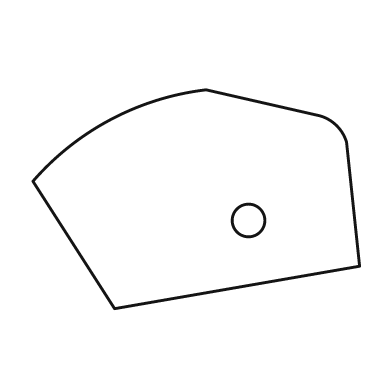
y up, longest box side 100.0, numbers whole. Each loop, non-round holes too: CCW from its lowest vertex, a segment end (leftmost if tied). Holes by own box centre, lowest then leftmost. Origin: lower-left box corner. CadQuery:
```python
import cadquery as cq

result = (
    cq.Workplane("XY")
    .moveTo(25.0, 0.0)
    .lineTo(100.0, 13.0)
    .lineTo(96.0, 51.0)
    .threePointArc((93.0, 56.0), (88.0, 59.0))
    .lineTo(53.0, 67.0)
    .threePointArc((24.0, 58.0), (0.0, 39.0))
    .close()
    .moveTo(66.0, 27.0)
    .circle(5.0)
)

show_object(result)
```